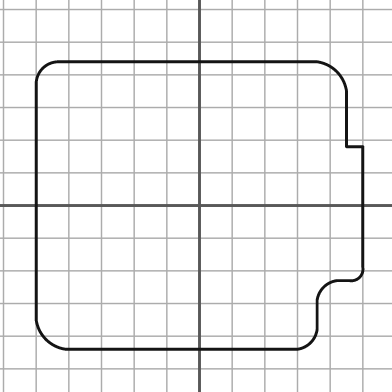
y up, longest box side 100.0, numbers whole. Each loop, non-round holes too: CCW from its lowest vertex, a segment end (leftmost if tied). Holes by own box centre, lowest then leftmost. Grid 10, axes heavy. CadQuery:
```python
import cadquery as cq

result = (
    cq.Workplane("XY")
    .moveTo(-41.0, -44.0)
    .lineTo(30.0, -44.0)
    .threePointArc((34.0, -42.0), (36.0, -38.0))
    .lineTo(36.0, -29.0)
    .threePointArc((38.0, -25.0), (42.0, -23.0))
    .lineTo(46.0, -23.0)
    .threePointArc((49.0, -22.0), (50.0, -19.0))
    .lineTo(50.0, 18.0)
    .lineTo(45.0, 18.0)
    .lineTo(45.0, 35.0)
    .threePointArc((42.0, 41.0), (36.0, 44.0))
    .lineTo(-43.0, 44.0)
    .threePointArc((-48.0, 42.0), (-50.0, 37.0))
    .lineTo(-50.0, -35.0)
    .threePointArc((-47.0, -41.0), (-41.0, -44.0))
    .close()
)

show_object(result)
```